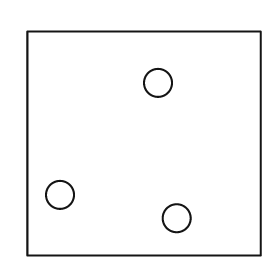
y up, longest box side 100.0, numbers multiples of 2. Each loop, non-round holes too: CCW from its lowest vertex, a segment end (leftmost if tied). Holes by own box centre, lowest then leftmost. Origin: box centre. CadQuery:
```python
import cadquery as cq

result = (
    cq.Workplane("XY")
    .moveTo(-50.0, -48.0)
    .lineTo(50.0, -48.0)
    .lineTo(50.0, 48.0)
    .lineTo(-50.0, 48.0)
    .close()
    .moveTo(14.0, -32.0)
    .circle(6.0)
    .moveTo(-36.0, -22.0)
    .circle(6.0)
    .moveTo(6.0, 26.0)
    .circle(6.0)
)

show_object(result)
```